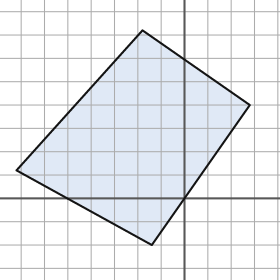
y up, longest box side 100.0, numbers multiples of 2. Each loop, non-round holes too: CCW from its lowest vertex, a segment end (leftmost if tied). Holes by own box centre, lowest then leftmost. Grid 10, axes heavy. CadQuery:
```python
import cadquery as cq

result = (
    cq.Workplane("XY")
    .moveTo(-14.0, -20.0)
    .lineTo(28.0, 40.0)
    .lineTo(-18.0, 72.0)
    .lineTo(-72.0, 12.0)
    .close()
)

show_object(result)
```